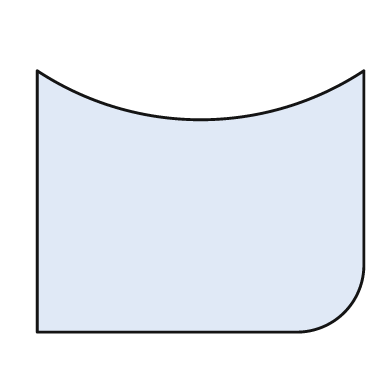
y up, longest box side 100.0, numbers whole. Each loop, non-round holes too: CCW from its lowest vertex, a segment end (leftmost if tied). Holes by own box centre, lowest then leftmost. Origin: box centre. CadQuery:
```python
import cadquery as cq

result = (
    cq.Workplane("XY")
    .moveTo(-50.0, -40.0)
    .lineTo(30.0, -40.0)
    .threePointArc((44.0, -34.0), (50.0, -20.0))
    .lineTo(50.0, 40.0)
    .threePointArc((0.0, 25.0), (-50.0, 40.0))
    .close()
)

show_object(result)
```